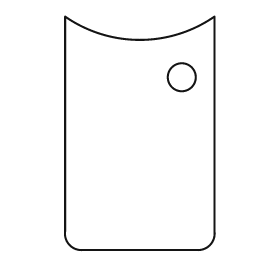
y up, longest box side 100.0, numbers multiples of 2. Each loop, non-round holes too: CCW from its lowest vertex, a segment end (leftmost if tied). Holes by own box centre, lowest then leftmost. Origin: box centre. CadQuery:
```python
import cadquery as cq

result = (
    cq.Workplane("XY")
    .moveTo(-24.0, -50.0)
    .lineTo(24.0, -50.0)
    .threePointArc((30.0, -48.0), (32.0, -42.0))
    .lineTo(32.0, 50.0)
    .threePointArc((0.0, 40.0), (-32.0, 50.0))
    .lineTo(-32.0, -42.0)
    .threePointArc((-30.0, -48.0), (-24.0, -50.0))
    .close()
    .moveTo(18.0, 24.0)
    .circle(6.0)
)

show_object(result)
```